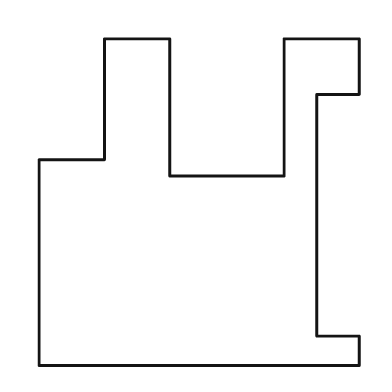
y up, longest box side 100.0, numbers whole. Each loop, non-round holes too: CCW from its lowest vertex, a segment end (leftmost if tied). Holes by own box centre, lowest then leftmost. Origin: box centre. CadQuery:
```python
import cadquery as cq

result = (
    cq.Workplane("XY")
    .moveTo(-49.0, -50.0)
    .lineTo(49.0, -50.0)
    .lineTo(49.0, -41.0)
    .lineTo(36.0, -41.0)
    .lineTo(36.0, 33.0)
    .lineTo(49.0, 33.0)
    .lineTo(49.0, 50.0)
    .lineTo(26.0, 50.0)
    .lineTo(26.0, 8.0)
    .lineTo(-9.0, 8.0)
    .lineTo(-9.0, 50.0)
    .lineTo(-29.0, 50.0)
    .lineTo(-29.0, 13.0)
    .lineTo(-49.0, 13.0)
    .close()
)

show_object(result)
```